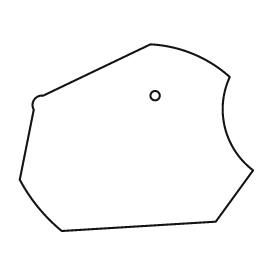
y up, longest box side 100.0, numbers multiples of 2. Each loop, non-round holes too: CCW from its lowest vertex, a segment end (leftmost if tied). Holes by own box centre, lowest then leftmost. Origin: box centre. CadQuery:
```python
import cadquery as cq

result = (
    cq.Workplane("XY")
    .moveTo(-32.0, -40.0)
    .lineTo(34.0, -36.0)
    .lineTo(50.0, -14.0)
    .threePointArc((38.0, 4.0), (40.0, 26.0))
    .threePointArc((24.0, 36.0), (6.0, 40.0))
    .lineTo(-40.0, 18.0)
    .threePointArc((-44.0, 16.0), (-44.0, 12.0))
    .lineTo(-50.0, -18.0)
    .threePointArc((-42.0, -30.0), (-32.0, -40.0))
    .close()
    .moveTo(8.0, 18.0)
    .circle(2.0)
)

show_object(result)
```